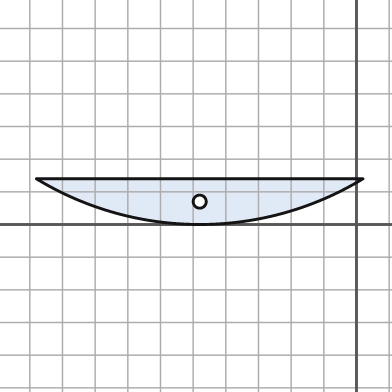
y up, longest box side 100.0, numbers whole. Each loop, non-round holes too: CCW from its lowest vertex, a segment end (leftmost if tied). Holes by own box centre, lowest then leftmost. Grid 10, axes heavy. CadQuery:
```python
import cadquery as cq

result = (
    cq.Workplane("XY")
    .moveTo(-98.0, 14.0)
    .threePointArc((-48.0, 0.0), (2.0, 14.0))
    .close()
    .moveTo(-48.0, 7.0)
    .circle(2.0)
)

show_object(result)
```